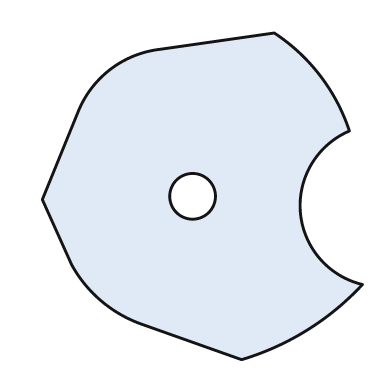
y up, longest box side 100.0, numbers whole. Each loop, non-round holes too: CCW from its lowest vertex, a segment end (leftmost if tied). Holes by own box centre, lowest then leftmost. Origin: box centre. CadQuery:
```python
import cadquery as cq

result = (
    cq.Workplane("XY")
    .moveTo(12.0, -50.0)
    .threePointArc((32.0, -41.0), (49.0, -27.0))
    .threePointArc((30.0, -5.0), (45.0, 20.0))
    .threePointArc((36.0, 37.0), (22.0, 50.0))
    .lineTo(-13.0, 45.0)
    .threePointArc((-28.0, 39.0), (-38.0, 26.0))
    .lineTo(-49.0, -1.0)
    .lineTo(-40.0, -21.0)
    .threePointArc((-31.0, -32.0), (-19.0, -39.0))
    .close()
    .moveTo(-3.0, 0.0)
    .circle(7.0)
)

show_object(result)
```